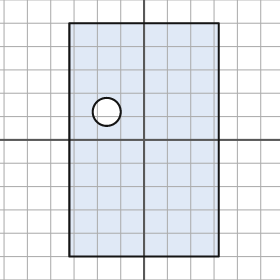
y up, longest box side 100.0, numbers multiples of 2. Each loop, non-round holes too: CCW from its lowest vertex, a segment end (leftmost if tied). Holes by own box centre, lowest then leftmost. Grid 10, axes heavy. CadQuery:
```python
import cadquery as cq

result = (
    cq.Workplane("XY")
    .moveTo(-32.0, -50.0)
    .lineTo(32.0, -50.0)
    .lineTo(32.0, 50.0)
    .lineTo(-32.0, 50.0)
    .close()
    .moveTo(-16.0, 12.0)
    .circle(6.0)
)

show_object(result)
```